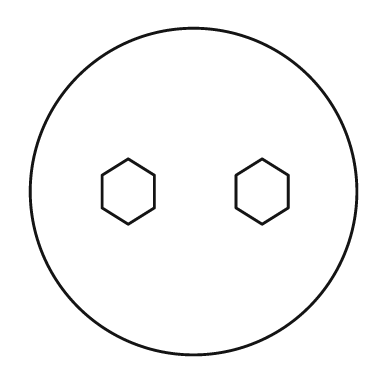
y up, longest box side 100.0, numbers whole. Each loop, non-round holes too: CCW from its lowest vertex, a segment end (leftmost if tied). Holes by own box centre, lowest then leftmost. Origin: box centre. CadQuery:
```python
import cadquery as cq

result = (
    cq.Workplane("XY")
    .moveTo(0.0, 0.0)
    .circle(50.0)
    .moveTo(-20.0, -10.0)
    .lineTo(-12.0, -5.0)
    .lineTo(-12.0, 5.0)
    .lineTo(-20.0, 10.0)
    .lineTo(-28.0, 5.0)
    .lineTo(-28.0, -5.0)
    .close()
    .moveTo(21.0, -10.0)
    .lineTo(29.0, -5.0)
    .lineTo(29.0, 5.0)
    .lineTo(21.0, 10.0)
    .lineTo(13.0, 5.0)
    .lineTo(13.0, -5.0)
    .close()
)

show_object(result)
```